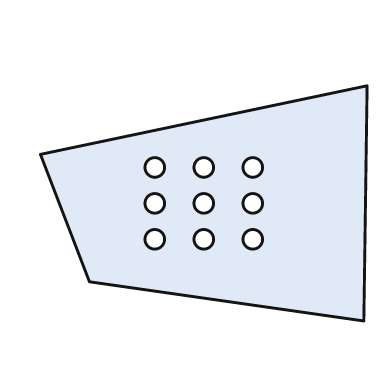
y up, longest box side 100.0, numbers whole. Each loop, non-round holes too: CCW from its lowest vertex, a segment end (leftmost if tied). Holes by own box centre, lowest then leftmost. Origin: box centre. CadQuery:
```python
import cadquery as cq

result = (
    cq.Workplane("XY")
    .moveTo(49.0, -36.0)
    .lineTo(50.0, 36.0)
    .lineTo(-50.0, 15.0)
    .lineTo(-35.0, -24.0)
    .close()
    .moveTo(-15.0, -11.0)
    .circle(3.0)
    .moveTo(0.0, -11.0)
    .circle(3.0)
    .moveTo(15.0, -11.0)
    .circle(3.0)
    .moveTo(-15.0, 0.0)
    .circle(3.0)
    .moveTo(0.0, 0.0)
    .circle(3.0)
    .moveTo(15.0, 0.0)
    .circle(3.0)
    .moveTo(-15.0, 11.0)
    .circle(3.0)
    .moveTo(0.0, 11.0)
    .circle(3.0)
    .moveTo(15.0, 11.0)
    .circle(3.0)
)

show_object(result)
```